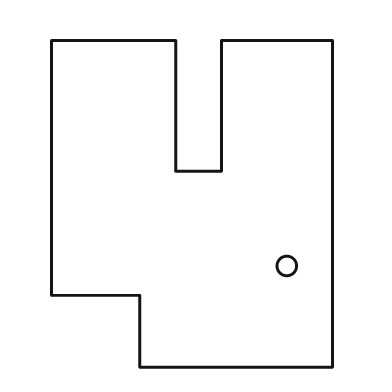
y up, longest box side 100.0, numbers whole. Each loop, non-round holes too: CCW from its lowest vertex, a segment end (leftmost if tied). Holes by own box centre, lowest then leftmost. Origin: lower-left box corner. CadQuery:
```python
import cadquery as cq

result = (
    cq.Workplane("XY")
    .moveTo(27.0, 0.0)
    .lineTo(86.0, 0.0)
    .lineTo(86.0, 100.0)
    .lineTo(52.0, 100.0)
    .lineTo(52.0, 60.0)
    .lineTo(38.0, 60.0)
    .lineTo(38.0, 100.0)
    .lineTo(0.0, 100.0)
    .lineTo(0.0, 22.0)
    .lineTo(27.0, 22.0)
    .close()
    .moveTo(72.0, 31.0)
    .circle(3.0)
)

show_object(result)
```